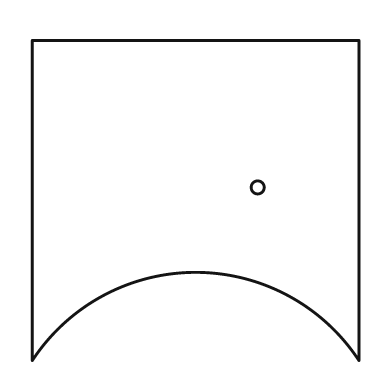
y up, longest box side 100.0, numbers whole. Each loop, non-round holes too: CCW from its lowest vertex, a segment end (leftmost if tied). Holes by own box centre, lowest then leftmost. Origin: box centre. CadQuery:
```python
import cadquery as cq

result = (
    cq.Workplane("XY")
    .moveTo(-50.0, -49.0)
    .threePointArc((0.0, -22.0), (50.0, -49.0))
    .lineTo(50.0, 49.0)
    .lineTo(-50.0, 49.0)
    .close()
    .moveTo(19.0, 4.0)
    .circle(2.0)
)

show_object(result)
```